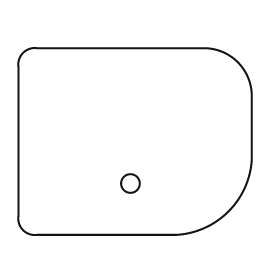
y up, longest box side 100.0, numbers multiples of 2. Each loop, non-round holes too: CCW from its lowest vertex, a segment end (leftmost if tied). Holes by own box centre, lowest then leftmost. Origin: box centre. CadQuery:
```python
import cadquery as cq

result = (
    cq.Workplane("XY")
    .moveTo(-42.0, -40.0)
    .lineTo(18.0, -40.0)
    .threePointArc((40.0, -30.0), (50.0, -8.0))
    .lineTo(50.0, 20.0)
    .threePointArc((44.0, 34.0), (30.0, 40.0))
    .lineTo(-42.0, 40.0)
    .threePointArc((-48.0, 38.0), (-50.0, 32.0))
    .lineTo(-50.0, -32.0)
    .threePointArc((-48.0, -38.0), (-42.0, -40.0))
    .close()
    .moveTo(-2.0, -18.0)
    .circle(4.0)
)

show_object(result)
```